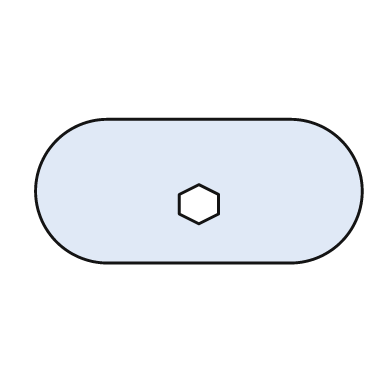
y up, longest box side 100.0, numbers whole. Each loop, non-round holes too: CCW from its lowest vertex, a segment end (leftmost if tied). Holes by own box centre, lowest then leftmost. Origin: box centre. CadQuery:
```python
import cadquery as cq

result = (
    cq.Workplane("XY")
    .moveTo(-28.0, -22.0)
    .lineTo(28.0, -22.0)
    .threePointArc((50.0, 0.0), (28.0, 22.0))
    .lineTo(-28.0, 22.0)
    .threePointArc((-50.0, 0.0), (-28.0, -22.0))
    .close()
    .moveTo(0.0, -10.0)
    .lineTo(6.0, -7.0)
    .lineTo(6.0, -1.0)
    .lineTo(0.0, 2.0)
    .lineTo(-6.0, -1.0)
    .lineTo(-6.0, -7.0)
    .close()
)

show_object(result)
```